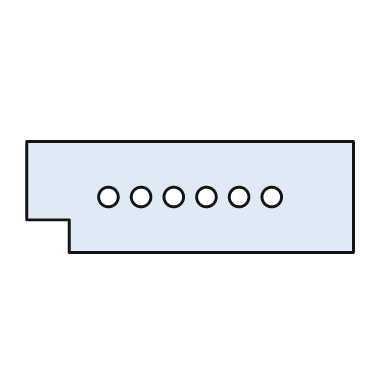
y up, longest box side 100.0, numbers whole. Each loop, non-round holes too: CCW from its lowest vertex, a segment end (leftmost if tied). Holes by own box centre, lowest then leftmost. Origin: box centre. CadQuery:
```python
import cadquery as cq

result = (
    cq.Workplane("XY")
    .moveTo(-37.0, -17.0)
    .lineTo(50.0, -17.0)
    .lineTo(50.0, 17.0)
    .lineTo(-50.0, 17.0)
    .lineTo(-50.0, -7.0)
    .lineTo(-37.0, -7.0)
    .close()
    .moveTo(-25.0, 0.0)
    .circle(3.0)
    .moveTo(-15.0, 0.0)
    .circle(3.0)
    .moveTo(-5.0, 0.0)
    .circle(3.0)
    .moveTo(5.0, 0.0)
    .circle(3.0)
    .moveTo(15.0, 0.0)
    .circle(3.0)
    .moveTo(25.0, 0.0)
    .circle(3.0)
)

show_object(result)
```